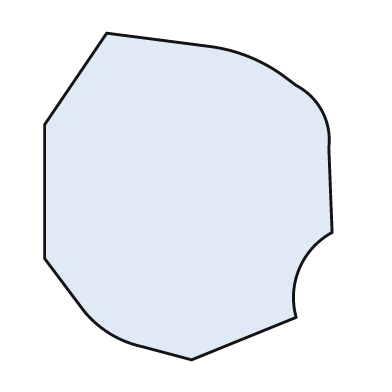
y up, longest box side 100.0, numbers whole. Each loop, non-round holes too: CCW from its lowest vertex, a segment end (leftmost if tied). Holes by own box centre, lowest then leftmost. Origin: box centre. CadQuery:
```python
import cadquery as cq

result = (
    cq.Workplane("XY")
    .moveTo(1.0, -50.0)
    .lineTo(33.0, -37.0)
    .threePointArc((34.0, -22.0), (44.0, -11.0))
    .lineTo(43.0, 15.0)
    .threePointArc((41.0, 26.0), (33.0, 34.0))
    .lineTo(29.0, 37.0)
    .threePointArc((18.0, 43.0), (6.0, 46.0))
    .lineTo(-25.0, 50.0)
    .lineTo(-44.0, 22.0)
    .lineTo(-44.0, -19.0)
    .lineTo(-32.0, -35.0)
    .threePointArc((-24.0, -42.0), (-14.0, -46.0))
    .close()
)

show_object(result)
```